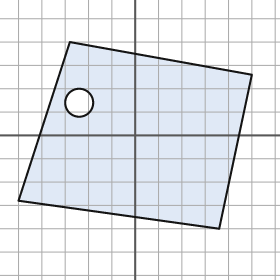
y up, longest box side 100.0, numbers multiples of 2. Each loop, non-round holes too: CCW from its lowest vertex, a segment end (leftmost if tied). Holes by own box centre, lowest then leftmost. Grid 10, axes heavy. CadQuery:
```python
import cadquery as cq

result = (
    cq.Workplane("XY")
    .moveTo(36.0, -40.0)
    .lineTo(50.0, 26.0)
    .lineTo(-28.0, 40.0)
    .lineTo(-50.0, -28.0)
    .close()
    .moveTo(-24.0, 14.0)
    .circle(6.0)
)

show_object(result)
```